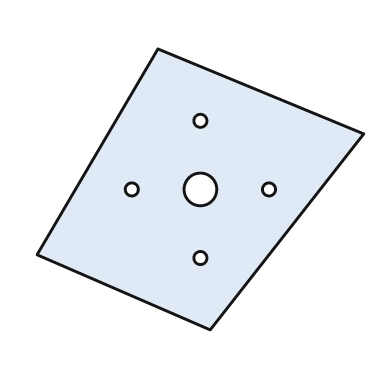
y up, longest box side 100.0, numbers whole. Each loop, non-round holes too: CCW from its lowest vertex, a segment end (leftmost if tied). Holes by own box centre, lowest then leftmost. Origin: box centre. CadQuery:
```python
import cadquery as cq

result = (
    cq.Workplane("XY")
    .moveTo(3.0, -43.0)
    .lineTo(50.0, 17.0)
    .lineTo(-13.0, 43.0)
    .lineTo(-50.0, -20.0)
    .close()
    .moveTo(0.0, -21.0)
    .circle(2.0)
    .moveTo(-21.0, 0.0)
    .circle(2.0)
    .moveTo(0.0, 0.0)
    .circle(5.0)
    .moveTo(21.0, 0.0)
    .circle(2.0)
    .moveTo(0.0, 21.0)
    .circle(2.0)
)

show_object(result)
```